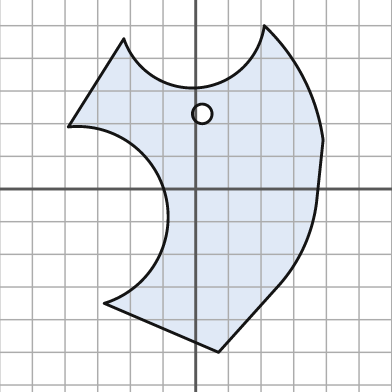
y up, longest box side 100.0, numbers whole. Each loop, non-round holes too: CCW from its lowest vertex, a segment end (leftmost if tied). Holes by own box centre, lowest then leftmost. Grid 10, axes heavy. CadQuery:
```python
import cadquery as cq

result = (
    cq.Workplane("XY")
    .moveTo(7.0, -50.0)
    .lineTo(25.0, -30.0)
    .threePointArc((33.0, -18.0), (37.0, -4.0))
    .lineTo(39.0, 15.0)
    .threePointArc((33.0, 34.0), (21.0, 50.0))
    .threePointArc((1.0, 31.0), (-22.0, 46.0))
    .lineTo(-39.0, 19.0)
    .threePointArc((-9.0, -3.0), (-28.0, -35.0))
    .close()
    .moveTo(2.0, 23.0)
    .circle(3.0)
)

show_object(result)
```